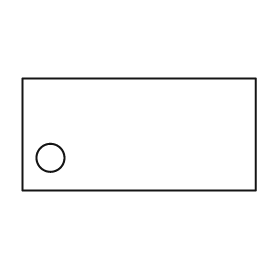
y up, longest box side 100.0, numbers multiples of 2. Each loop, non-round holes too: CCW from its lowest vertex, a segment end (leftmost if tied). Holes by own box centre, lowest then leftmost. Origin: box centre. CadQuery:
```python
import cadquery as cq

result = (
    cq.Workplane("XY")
    .moveTo(-50.0, -24.0)
    .lineTo(50.0, -24.0)
    .lineTo(50.0, 24.0)
    .lineTo(-50.0, 24.0)
    .close()
    .moveTo(-38.0, -10.0)
    .circle(6.0)
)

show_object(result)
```